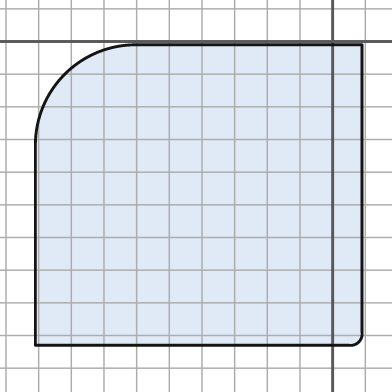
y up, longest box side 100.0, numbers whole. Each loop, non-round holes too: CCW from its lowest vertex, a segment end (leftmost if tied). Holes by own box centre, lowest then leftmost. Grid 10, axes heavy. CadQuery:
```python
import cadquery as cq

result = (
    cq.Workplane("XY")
    .moveTo(-91.0, -93.0)
    .lineTo(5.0, -93.0)
    .threePointArc((8.0, -92.0), (9.0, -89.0))
    .lineTo(9.0, -1.0)
    .lineTo(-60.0, -1.0)
    .threePointArc((-82.0, -10.0), (-91.0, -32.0))
    .close()
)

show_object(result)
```